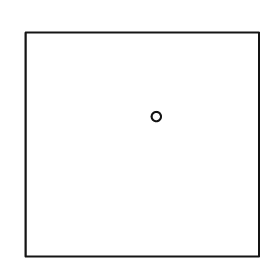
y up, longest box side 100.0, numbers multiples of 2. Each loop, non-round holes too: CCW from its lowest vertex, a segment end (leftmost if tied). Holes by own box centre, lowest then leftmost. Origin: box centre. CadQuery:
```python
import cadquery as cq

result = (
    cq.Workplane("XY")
    .moveTo(-50.0, -48.0)
    .lineTo(50.0, -48.0)
    .lineTo(50.0, 48.0)
    .lineTo(-50.0, 48.0)
    .close()
    .moveTo(6.0, 12.0)
    .circle(2.0)
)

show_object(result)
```